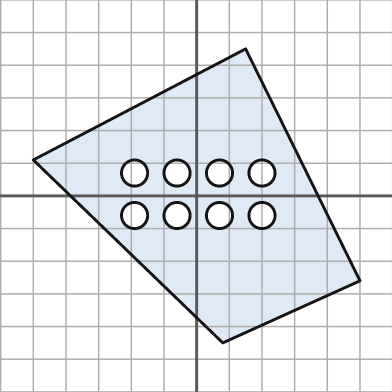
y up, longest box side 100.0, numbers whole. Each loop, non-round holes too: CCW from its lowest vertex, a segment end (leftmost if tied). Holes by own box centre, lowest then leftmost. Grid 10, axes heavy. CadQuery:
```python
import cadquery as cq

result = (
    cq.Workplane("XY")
    .moveTo(8.0, -45.0)
    .lineTo(50.0, -26.0)
    .lineTo(15.0, 45.0)
    .lineTo(-50.0, 11.0)
    .close()
    .moveTo(-19.0, -6.0)
    .circle(4.0)
    .moveTo(-6.0, -6.0)
    .circle(4.0)
    .moveTo(7.0, -6.0)
    .circle(4.0)
    .moveTo(20.0, -6.0)
    .circle(4.0)
    .moveTo(-19.0, 7.0)
    .circle(4.0)
    .moveTo(-6.0, 7.0)
    .circle(4.0)
    .moveTo(7.0, 7.0)
    .circle(4.0)
    .moveTo(20.0, 7.0)
    .circle(4.0)
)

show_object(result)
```